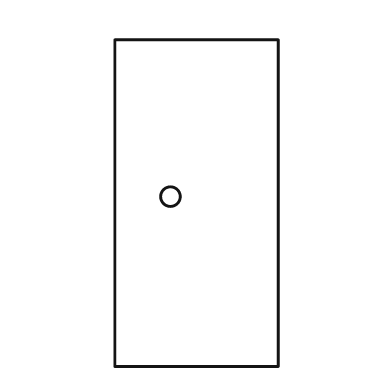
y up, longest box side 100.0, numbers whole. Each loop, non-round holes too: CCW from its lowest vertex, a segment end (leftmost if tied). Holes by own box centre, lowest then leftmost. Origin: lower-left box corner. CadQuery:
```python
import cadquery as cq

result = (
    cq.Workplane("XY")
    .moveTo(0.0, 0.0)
    .lineTo(50.0, 0.0)
    .lineTo(50.0, 100.0)
    .lineTo(0.0, 100.0)
    .close()
    .moveTo(17.0, 52.0)
    .circle(3.0)
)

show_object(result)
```